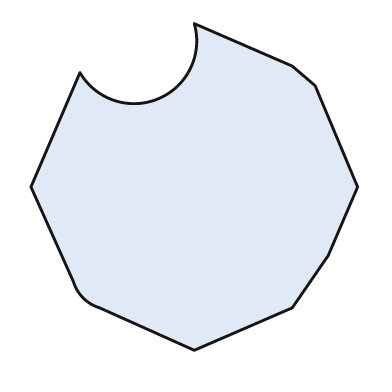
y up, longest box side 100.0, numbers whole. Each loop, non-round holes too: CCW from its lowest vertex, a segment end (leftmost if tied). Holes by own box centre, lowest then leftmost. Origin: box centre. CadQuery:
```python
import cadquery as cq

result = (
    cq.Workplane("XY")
    .moveTo(0.0, -50.0)
    .lineTo(30.0, -37.0)
    .lineTo(41.0, -21.0)
    .lineTo(50.0, 0.0)
    .lineTo(37.0, 31.0)
    .lineTo(30.0, 37.0)
    .lineTo(0.0, 50.0)
    .threePointArc((-11.0, 27.0), (-35.0, 35.0))
    .lineTo(-50.0, 0.0)
    .lineTo(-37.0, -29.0)
    .threePointArc((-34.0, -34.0), (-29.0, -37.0))
    .close()
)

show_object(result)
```